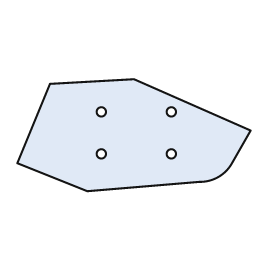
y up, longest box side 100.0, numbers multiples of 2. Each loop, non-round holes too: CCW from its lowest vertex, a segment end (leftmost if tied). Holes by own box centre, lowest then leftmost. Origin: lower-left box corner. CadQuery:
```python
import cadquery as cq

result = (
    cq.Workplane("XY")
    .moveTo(30.0, 0.0)
    .lineTo(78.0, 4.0)
    .threePointArc((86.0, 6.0), (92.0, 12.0))
    .lineTo(100.0, 26.0)
    .lineTo(50.0, 48.0)
    .lineTo(14.0, 46.0)
    .lineTo(0.0, 12.0)
    .close()
    .moveTo(36.0, 16.0)
    .circle(2.0)
    .moveTo(66.0, 16.0)
    .circle(2.0)
    .moveTo(36.0, 34.0)
    .circle(2.0)
    .moveTo(66.0, 34.0)
    .circle(2.0)
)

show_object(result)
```